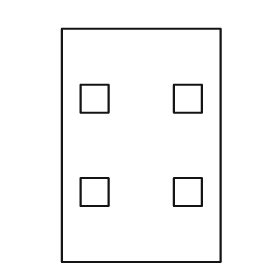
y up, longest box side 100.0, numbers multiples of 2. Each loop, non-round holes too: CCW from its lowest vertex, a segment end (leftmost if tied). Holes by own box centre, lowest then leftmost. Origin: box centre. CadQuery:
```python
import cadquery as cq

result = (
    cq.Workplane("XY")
    .moveTo(-34.0, -50.0)
    .lineTo(34.0, -50.0)
    .lineTo(34.0, 50.0)
    .lineTo(-34.0, 50.0)
    .close()
    .moveTo(-26.0, -26.0)
    .lineTo(-14.0, -26.0)
    .lineTo(-14.0, -14.0)
    .lineTo(-26.0, -14.0)
    .close()
    .moveTo(14.0, -26.0)
    .lineTo(26.0, -26.0)
    .lineTo(26.0, -14.0)
    .lineTo(14.0, -14.0)
    .close()
    .moveTo(-26.0, 14.0)
    .lineTo(-14.0, 14.0)
    .lineTo(-14.0, 26.0)
    .lineTo(-26.0, 26.0)
    .close()
    .moveTo(14.0, 14.0)
    .lineTo(26.0, 14.0)
    .lineTo(26.0, 26.0)
    .lineTo(14.0, 26.0)
    .close()
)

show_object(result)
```